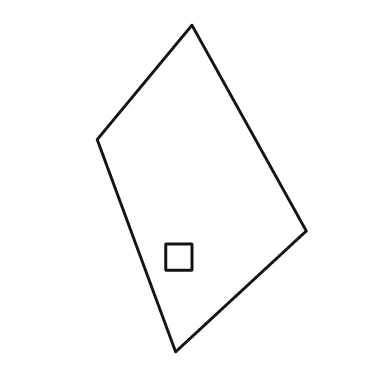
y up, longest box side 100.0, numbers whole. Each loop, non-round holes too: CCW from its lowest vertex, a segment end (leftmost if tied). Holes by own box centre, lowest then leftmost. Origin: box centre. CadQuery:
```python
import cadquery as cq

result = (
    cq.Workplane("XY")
    .moveTo(-8.0, -50.0)
    .lineTo(32.0, -13.0)
    .lineTo(-3.0, 50.0)
    .lineTo(-32.0, 15.0)
    .close()
    .moveTo(-11.0, -25.0)
    .lineTo(-3.0, -25.0)
    .lineTo(-3.0, -17.0)
    .lineTo(-11.0, -17.0)
    .close()
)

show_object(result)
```